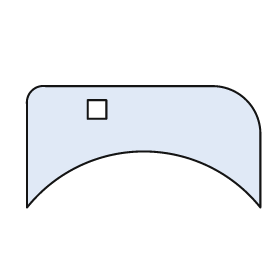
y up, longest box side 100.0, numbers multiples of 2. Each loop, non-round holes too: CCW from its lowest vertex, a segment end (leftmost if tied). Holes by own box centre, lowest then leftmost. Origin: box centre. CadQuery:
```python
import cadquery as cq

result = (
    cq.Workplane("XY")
    .moveTo(-50.0, -26.0)
    .threePointArc((0.0, -2.0), (50.0, -26.0))
    .lineTo(50.0, 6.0)
    .threePointArc((44.0, 20.0), (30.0, 26.0))
    .lineTo(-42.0, 26.0)
    .threePointArc((-48.0, 24.0), (-50.0, 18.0))
    .close()
    .moveTo(-24.0, 12.0)
    .lineTo(-16.0, 12.0)
    .lineTo(-16.0, 20.0)
    .lineTo(-24.0, 20.0)
    .close()
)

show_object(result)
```